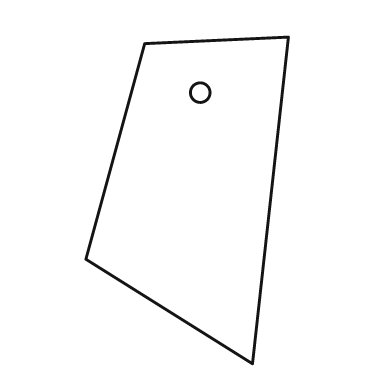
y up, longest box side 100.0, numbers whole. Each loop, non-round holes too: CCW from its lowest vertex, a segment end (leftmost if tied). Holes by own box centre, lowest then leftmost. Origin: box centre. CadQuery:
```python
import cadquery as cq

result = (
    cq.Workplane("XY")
    .moveTo(20.0, -50.0)
    .lineTo(31.0, 50.0)
    .lineTo(-13.0, 48.0)
    .lineTo(-31.0, -18.0)
    .close()
    .moveTo(4.0, 33.0)
    .circle(3.0)
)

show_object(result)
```